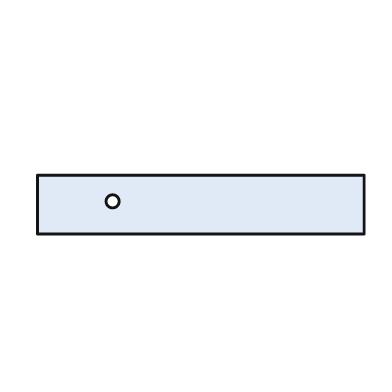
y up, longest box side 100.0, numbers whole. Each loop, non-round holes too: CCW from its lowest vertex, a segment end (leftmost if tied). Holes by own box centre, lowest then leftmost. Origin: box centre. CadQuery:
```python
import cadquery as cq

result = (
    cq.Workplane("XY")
    .moveTo(-50.0, -9.0)
    .lineTo(50.0, -9.0)
    .lineTo(50.0, 9.0)
    .lineTo(-50.0, 9.0)
    .close()
    .moveTo(-27.0, 1.0)
    .circle(2.0)
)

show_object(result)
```